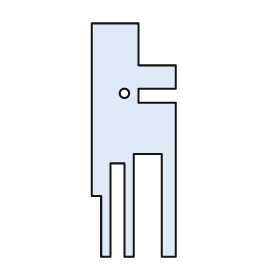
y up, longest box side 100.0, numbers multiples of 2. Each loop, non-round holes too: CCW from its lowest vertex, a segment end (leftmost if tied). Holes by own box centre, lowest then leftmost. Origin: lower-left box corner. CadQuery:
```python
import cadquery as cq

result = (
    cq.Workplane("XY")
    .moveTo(4.0, 0.0)
    .lineTo(8.0, 0.0)
    .lineTo(8.0, 40.0)
    .lineTo(14.0, 40.0)
    .lineTo(14.0, 0.0)
    .lineTo(18.0, 0.0)
    .lineTo(18.0, 44.0)
    .lineTo(30.0, 44.0)
    .lineTo(30.0, 0.0)
    .lineTo(36.0, 0.0)
    .lineTo(36.0, 66.0)
    .lineTo(20.0, 66.0)
    .lineTo(20.0, 72.0)
    .lineTo(36.0, 72.0)
    .lineTo(36.0, 82.0)
    .lineTo(20.0, 82.0)
    .lineTo(20.0, 100.0)
    .lineTo(0.0, 100.0)
    .lineTo(0.0, 26.0)
    .lineTo(4.0, 26.0)
    .close()
    .moveTo(14.0, 70.0)
    .circle(2.0)
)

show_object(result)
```